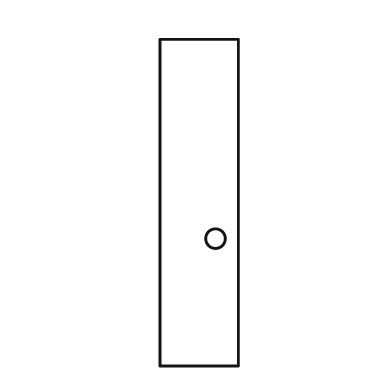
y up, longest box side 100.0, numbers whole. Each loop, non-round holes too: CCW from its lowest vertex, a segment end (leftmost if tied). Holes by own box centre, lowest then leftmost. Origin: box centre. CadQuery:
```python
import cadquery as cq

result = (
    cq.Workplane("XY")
    .moveTo(-12.0, -50.0)
    .lineTo(12.0, -50.0)
    .lineTo(12.0, 50.0)
    .lineTo(-12.0, 50.0)
    .close()
    .moveTo(5.0, -11.0)
    .circle(3.0)
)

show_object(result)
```